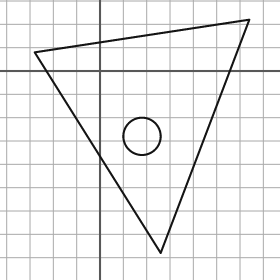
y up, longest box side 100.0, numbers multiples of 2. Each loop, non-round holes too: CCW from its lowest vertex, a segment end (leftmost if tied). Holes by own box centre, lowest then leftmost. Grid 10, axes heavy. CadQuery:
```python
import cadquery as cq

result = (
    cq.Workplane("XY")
    .moveTo(26.0, -78.0)
    .lineTo(64.0, 22.0)
    .lineTo(-28.0, 8.0)
    .close()
    .moveTo(18.0, -28.0)
    .circle(8.0)
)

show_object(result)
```